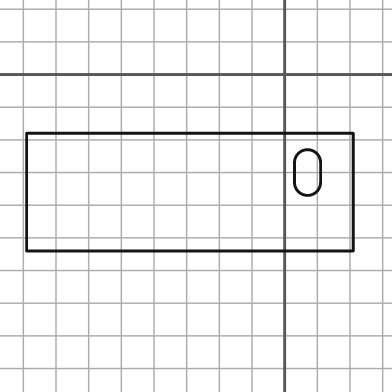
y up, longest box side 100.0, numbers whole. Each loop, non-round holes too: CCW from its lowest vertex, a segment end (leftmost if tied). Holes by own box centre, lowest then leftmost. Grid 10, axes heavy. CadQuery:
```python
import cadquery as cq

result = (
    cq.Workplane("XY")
    .moveTo(-79.0, -54.0)
    .lineTo(21.0, -54.0)
    .lineTo(21.0, -18.0)
    .lineTo(-79.0, -18.0)
    .close()
    .moveTo(3.0, -33.0)
    .threePointArc((7.0, -37.0), (11.0, -33.0))
    .lineTo(11.0, -27.0)
    .threePointArc((7.0, -23.0), (3.0, -27.0))
    .close()
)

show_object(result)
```